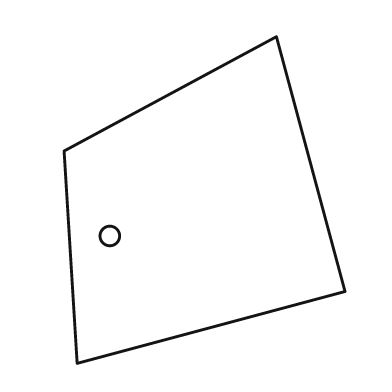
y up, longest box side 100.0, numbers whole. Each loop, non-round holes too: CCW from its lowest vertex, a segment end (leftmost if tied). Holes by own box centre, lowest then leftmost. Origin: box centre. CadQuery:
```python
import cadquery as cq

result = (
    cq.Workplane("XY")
    .moveTo(-39.0, -50.0)
    .lineTo(43.0, -28.0)
    .lineTo(22.0, 50.0)
    .lineTo(-43.0, 15.0)
    .close()
    .moveTo(-29.0, -11.0)
    .circle(3.0)
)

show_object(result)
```